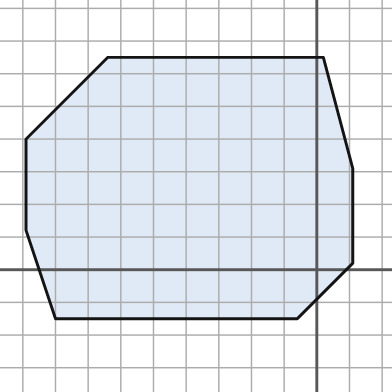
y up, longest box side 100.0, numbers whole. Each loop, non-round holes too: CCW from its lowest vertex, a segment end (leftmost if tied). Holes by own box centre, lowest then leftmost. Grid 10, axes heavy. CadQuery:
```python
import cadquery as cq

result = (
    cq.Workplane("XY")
    .moveTo(-80.0, -15.0)
    .lineTo(-6.0, -15.0)
    .lineTo(11.0, 2.0)
    .lineTo(11.0, 31.0)
    .lineTo(2.0, 65.0)
    .lineTo(-64.0, 65.0)
    .lineTo(-89.0, 40.0)
    .lineTo(-89.0, 12.0)
    .close()
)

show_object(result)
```